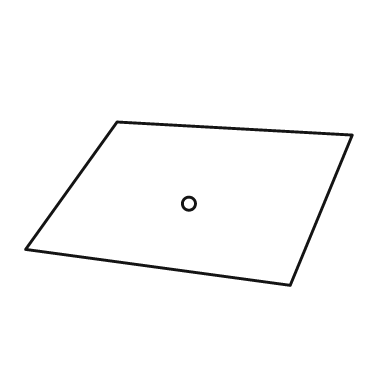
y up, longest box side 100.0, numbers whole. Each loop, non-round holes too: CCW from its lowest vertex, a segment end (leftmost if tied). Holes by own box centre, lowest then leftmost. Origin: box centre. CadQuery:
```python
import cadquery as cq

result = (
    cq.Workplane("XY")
    .moveTo(31.0, -25.0)
    .lineTo(50.0, 21.0)
    .lineTo(-22.0, 25.0)
    .lineTo(-50.0, -14.0)
    .close()
    .moveTo(0.0, 0.0)
    .circle(2.0)
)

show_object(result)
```